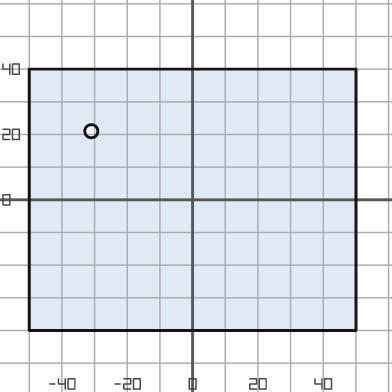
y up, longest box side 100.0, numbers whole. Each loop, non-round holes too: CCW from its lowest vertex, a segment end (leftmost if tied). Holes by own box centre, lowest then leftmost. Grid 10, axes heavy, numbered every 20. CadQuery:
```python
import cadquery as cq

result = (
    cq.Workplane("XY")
    .moveTo(-50.0, -40.0)
    .lineTo(50.0, -40.0)
    .lineTo(50.0, 40.0)
    .lineTo(-50.0, 40.0)
    .close()
    .moveTo(-31.0, 21.0)
    .circle(2.0)
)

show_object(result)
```